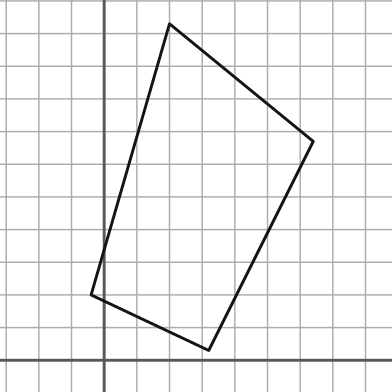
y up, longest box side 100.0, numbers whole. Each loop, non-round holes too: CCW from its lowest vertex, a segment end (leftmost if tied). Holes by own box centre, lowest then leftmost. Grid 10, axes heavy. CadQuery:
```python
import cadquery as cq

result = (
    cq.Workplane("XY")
    .moveTo(32.0, 3.0)
    .lineTo(64.0, 67.0)
    .lineTo(20.0, 103.0)
    .lineTo(-4.0, 20.0)
    .close()
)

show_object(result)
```